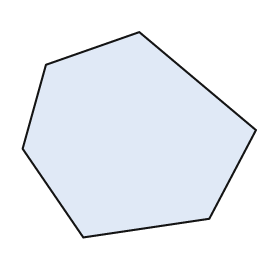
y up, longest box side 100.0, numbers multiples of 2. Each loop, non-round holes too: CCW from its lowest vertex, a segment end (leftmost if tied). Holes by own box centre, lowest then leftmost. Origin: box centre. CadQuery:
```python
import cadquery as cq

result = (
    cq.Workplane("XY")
    .moveTo(-24.0, -44.0)
    .lineTo(30.0, -36.0)
    .lineTo(50.0, 2.0)
    .lineTo(0.0, 44.0)
    .lineTo(-40.0, 30.0)
    .lineTo(-50.0, -6.0)
    .close()
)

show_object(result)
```